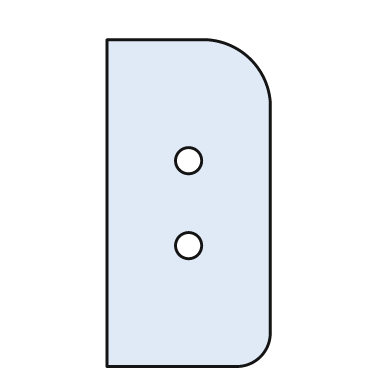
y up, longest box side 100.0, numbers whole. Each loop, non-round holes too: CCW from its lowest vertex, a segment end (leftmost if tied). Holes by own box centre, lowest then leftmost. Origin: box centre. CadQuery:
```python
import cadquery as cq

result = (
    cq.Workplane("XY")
    .moveTo(-25.0, -50.0)
    .lineTo(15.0, -50.0)
    .threePointArc((22.0, -47.0), (25.0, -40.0))
    .lineTo(25.0, 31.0)
    .threePointArc((19.0, 44.0), (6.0, 50.0))
    .lineTo(-25.0, 50.0)
    .close()
    .moveTo(0.0, -13.0)
    .circle(4.0)
    .moveTo(0.0, 13.0)
    .circle(4.0)
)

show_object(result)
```